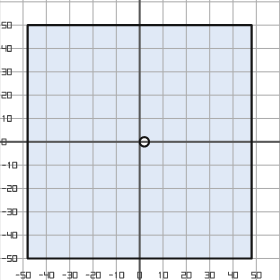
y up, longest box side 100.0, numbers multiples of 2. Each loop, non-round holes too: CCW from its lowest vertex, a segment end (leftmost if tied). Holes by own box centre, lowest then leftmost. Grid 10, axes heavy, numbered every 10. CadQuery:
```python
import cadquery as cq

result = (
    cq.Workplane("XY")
    .moveTo(-48.0, -50.0)
    .lineTo(48.0, -50.0)
    .lineTo(48.0, 50.0)
    .lineTo(-48.0, 50.0)
    .close()
    .moveTo(2.0, 0.0)
    .circle(2.0)
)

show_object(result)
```